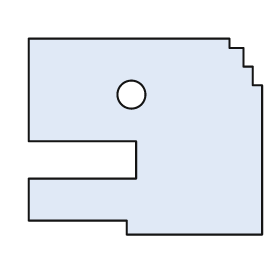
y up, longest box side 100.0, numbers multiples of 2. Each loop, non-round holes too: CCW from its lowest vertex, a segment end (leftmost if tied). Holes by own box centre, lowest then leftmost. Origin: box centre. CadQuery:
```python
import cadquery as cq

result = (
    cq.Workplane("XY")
    .moveTo(-8.0, -42.0)
    .lineTo(50.0, -42.0)
    .lineTo(50.0, 22.0)
    .lineTo(46.0, 22.0)
    .lineTo(46.0, 30.0)
    .lineTo(42.0, 30.0)
    .lineTo(42.0, 38.0)
    .lineTo(36.0, 38.0)
    .lineTo(36.0, 42.0)
    .lineTo(-50.0, 42.0)
    .lineTo(-50.0, -2.0)
    .lineTo(-4.0, -2.0)
    .lineTo(-4.0, -18.0)
    .lineTo(-50.0, -18.0)
    .lineTo(-50.0, -36.0)
    .lineTo(-8.0, -36.0)
    .close()
    .moveTo(-6.0, 18.0)
    .circle(6.0)
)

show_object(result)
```